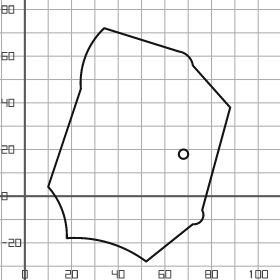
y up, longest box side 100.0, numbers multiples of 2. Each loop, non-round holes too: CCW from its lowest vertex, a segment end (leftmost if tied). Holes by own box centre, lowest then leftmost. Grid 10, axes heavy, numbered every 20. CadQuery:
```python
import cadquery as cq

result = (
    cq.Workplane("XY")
    .moveTo(52.0, -28.0)
    .lineTo(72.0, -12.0)
    .threePointArc((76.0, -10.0), (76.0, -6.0))
    .lineTo(88.0, 38.0)
    .lineTo(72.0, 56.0)
    .threePointArc((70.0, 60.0), (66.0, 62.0))
    .lineTo(34.0, 72.0)
    .threePointArc((26.0, 60.0), (24.0, 46.0))
    .lineTo(10.0, 4.0)
    .threePointArc((16.0, -6.0), (18.0, -18.0))
    .threePointArc((36.0, -20.0), (52.0, -28.0))
    .close()
    .moveTo(68.0, 18.0)
    .circle(2.0)
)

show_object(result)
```